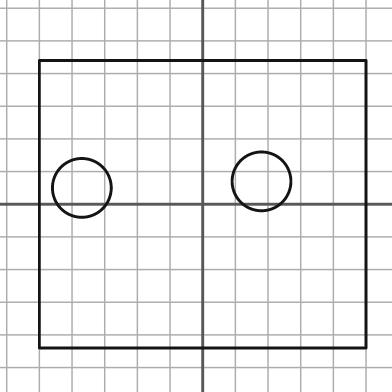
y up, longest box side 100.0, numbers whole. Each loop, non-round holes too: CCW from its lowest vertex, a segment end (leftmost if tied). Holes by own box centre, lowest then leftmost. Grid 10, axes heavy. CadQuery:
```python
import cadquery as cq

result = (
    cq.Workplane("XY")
    .moveTo(-50.0, -44.0)
    .lineTo(50.0, -44.0)
    .lineTo(50.0, 44.0)
    .lineTo(-50.0, 44.0)
    .close()
    .moveTo(-37.0, 5.0)
    .circle(9.0)
    .moveTo(18.0, 7.0)
    .circle(9.0)
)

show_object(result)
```